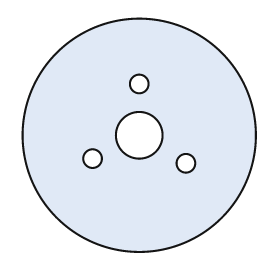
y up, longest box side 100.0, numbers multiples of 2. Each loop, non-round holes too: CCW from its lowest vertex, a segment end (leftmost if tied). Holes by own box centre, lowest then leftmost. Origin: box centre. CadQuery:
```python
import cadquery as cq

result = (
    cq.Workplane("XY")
    .moveTo(0.0, 0.0)
    .circle(50.0)
    .moveTo(20.0, -12.0)
    .circle(4.0)
    .moveTo(-20.0, -10.0)
    .circle(4.0)
    .moveTo(0.0, 0.0)
    .circle(10.0)
    .moveTo(0.0, 22.0)
    .circle(4.0)
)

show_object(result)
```